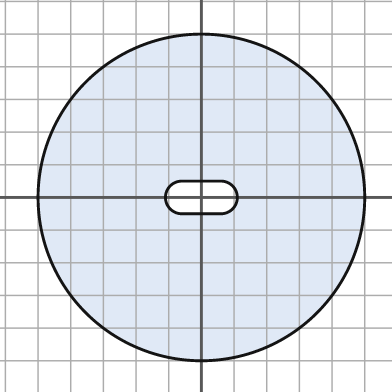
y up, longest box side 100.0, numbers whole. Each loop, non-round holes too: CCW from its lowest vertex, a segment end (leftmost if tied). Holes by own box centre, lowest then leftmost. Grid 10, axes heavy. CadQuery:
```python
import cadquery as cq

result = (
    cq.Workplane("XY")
    .moveTo(0.0, 0.0)
    .circle(50.0)
    .moveTo(-6.0, -5.0)
    .lineTo(6.0, -5.0)
    .threePointArc((11.0, 0.0), (6.0, 5.0))
    .lineTo(-6.0, 5.0)
    .threePointArc((-11.0, 0.0), (-6.0, -5.0))
    .close()
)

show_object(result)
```